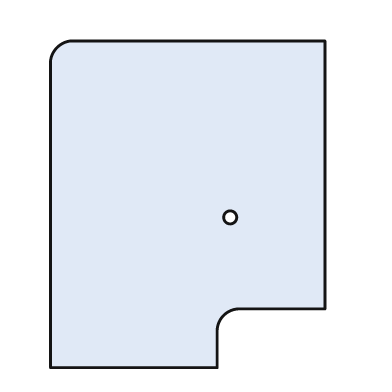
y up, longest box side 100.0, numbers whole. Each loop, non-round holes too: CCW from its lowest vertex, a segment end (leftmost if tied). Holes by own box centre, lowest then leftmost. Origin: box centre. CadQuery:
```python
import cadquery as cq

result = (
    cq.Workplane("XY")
    .moveTo(-42.0, -50.0)
    .lineTo(9.0, -50.0)
    .lineTo(9.0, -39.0)
    .threePointArc((11.0, -34.0), (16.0, -32.0))
    .lineTo(42.0, -32.0)
    .lineTo(42.0, 50.0)
    .lineTo(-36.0, 50.0)
    .threePointArc((-40.0, 48.0), (-42.0, 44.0))
    .close()
    .moveTo(13.0, -4.0)
    .circle(2.0)
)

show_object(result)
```